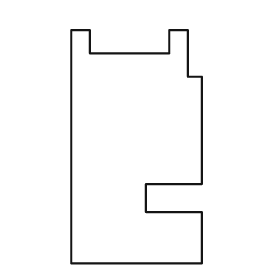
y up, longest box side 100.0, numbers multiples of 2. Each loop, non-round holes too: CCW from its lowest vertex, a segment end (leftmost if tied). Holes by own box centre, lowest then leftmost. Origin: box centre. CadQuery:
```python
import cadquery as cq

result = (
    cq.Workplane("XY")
    .moveTo(-28.0, -50.0)
    .lineTo(28.0, -50.0)
    .lineTo(28.0, -28.0)
    .lineTo(4.0, -28.0)
    .lineTo(4.0, -16.0)
    .lineTo(28.0, -16.0)
    .lineTo(28.0, 30.0)
    .lineTo(22.0, 30.0)
    .lineTo(22.0, 50.0)
    .lineTo(14.0, 50.0)
    .lineTo(14.0, 40.0)
    .lineTo(-20.0, 40.0)
    .lineTo(-20.0, 50.0)
    .lineTo(-28.0, 50.0)
    .close()
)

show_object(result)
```